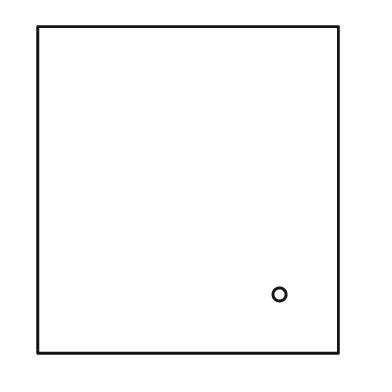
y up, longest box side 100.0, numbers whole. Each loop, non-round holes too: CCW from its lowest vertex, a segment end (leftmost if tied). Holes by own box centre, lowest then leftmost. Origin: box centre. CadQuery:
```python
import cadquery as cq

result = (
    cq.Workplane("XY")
    .moveTo(-46.0, -50.0)
    .lineTo(46.0, -50.0)
    .lineTo(46.0, 50.0)
    .lineTo(-46.0, 50.0)
    .close()
    .moveTo(28.0, -32.0)
    .circle(2.0)
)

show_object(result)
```